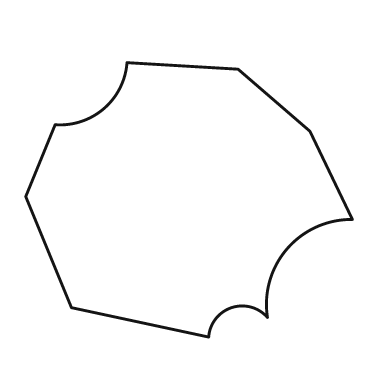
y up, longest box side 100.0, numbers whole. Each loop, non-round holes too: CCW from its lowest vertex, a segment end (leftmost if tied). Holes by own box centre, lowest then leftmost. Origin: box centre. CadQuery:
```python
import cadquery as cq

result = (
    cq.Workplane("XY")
    .moveTo(6.0, -42.0)
    .threePointArc((13.0, -33.0), (24.0, -36.0))
    .threePointArc((30.0, -15.0), (50.0, -6.0))
    .lineTo(37.0, 21.0)
    .lineTo(15.0, 40.0)
    .lineTo(-19.0, 42.0)
    .threePointArc((-26.0, 28.0), (-41.0, 23.0))
    .lineTo(-50.0, 1.0)
    .lineTo(-36.0, -33.0)
    .close()
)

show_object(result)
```